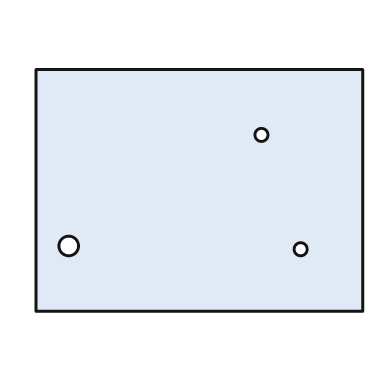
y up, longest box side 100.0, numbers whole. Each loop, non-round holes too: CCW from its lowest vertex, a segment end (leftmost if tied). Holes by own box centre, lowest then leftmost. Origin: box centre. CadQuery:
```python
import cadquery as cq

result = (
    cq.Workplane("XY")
    .moveTo(-50.0, -37.0)
    .lineTo(50.0, -37.0)
    .lineTo(50.0, 37.0)
    .lineTo(-50.0, 37.0)
    .close()
    .moveTo(31.0, -18.0)
    .circle(2.0)
    .moveTo(-40.0, -17.0)
    .circle(3.0)
    .moveTo(19.0, 17.0)
    .circle(2.0)
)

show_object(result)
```